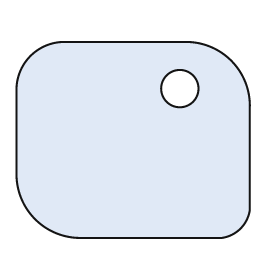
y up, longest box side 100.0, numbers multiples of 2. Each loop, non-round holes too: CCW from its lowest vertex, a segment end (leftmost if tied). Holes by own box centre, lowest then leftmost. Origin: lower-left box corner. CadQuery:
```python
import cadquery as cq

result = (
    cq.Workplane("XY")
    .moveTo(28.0, 0.0)
    .lineTo(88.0, 0.0)
    .threePointArc((96.0, 4.0), (100.0, 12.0))
    .lineTo(100.0, 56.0)
    .threePointArc((92.0, 76.0), (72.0, 84.0))
    .lineTo(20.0, 84.0)
    .threePointArc((6.0, 78.0), (0.0, 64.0))
    .lineTo(0.0, 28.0)
    .threePointArc((8.0, 8.0), (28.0, 0.0))
    .close()
    .moveTo(70.0, 64.0)
    .circle(8.0)
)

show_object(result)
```